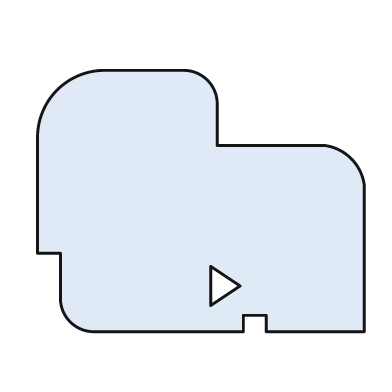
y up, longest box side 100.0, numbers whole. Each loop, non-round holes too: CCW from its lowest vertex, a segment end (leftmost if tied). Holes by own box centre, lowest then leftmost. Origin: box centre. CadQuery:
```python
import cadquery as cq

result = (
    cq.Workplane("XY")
    .moveTo(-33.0, -40.0)
    .lineTo(13.0, -40.0)
    .lineTo(13.0, -35.0)
    .lineTo(20.0, -35.0)
    .lineTo(20.0, -40.0)
    .lineTo(50.0, -40.0)
    .lineTo(50.0, 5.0)
    .threePointArc((46.0, 13.0), (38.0, 17.0))
    .lineTo(5.0, 17.0)
    .lineTo(5.0, 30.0)
    .threePointArc((2.0, 37.0), (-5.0, 40.0))
    .lineTo(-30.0, 40.0)
    .threePointArc((-44.0, 34.0), (-50.0, 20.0))
    .lineTo(-50.0, -16.0)
    .lineTo(-43.0, -16.0)
    .lineTo(-43.0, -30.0)
    .threePointArc((-40.0, -37.0), (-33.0, -40.0))
    .close()
    .moveTo(3.0, -32.0)
    .lineTo(12.0, -26.0)
    .lineTo(3.0, -20.0)
    .close()
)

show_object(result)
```